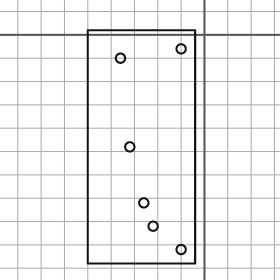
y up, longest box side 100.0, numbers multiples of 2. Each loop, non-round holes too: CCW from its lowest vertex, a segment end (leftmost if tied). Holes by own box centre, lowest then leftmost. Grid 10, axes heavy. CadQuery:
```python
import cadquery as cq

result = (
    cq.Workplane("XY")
    .moveTo(-50.0, -98.0)
    .lineTo(-4.0, -98.0)
    .lineTo(-4.0, 2.0)
    .lineTo(-50.0, 2.0)
    .close()
    .moveTo(-10.0, -92.0)
    .circle(2.0)
    .moveTo(-22.0, -82.0)
    .circle(2.0)
    .moveTo(-26.0, -72.0)
    .circle(2.0)
    .moveTo(-32.0, -48.0)
    .circle(2.0)
    .moveTo(-36.0, -10.0)
    .circle(2.0)
    .moveTo(-10.0, -6.0)
    .circle(2.0)
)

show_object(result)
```